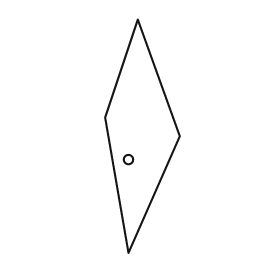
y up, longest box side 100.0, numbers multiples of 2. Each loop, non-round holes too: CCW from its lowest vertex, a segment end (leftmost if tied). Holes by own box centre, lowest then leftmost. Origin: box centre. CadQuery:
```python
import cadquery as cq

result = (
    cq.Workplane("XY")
    .moveTo(-6.0, -50.0)
    .lineTo(16.0, 0.0)
    .lineTo(-2.0, 50.0)
    .lineTo(-16.0, 8.0)
    .close()
    .moveTo(-6.0, -10.0)
    .circle(2.0)
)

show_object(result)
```